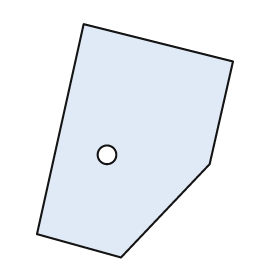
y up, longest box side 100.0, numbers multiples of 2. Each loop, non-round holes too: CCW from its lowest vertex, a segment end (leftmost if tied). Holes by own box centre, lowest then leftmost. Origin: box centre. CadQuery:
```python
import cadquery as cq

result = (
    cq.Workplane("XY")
    .moveTo(-6.0, -50.0)
    .lineTo(32.0, -10.0)
    .lineTo(42.0, 34.0)
    .lineTo(-22.0, 50.0)
    .lineTo(-42.0, -40.0)
    .close()
    .moveTo(-12.0, -6.0)
    .circle(4.0)
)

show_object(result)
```